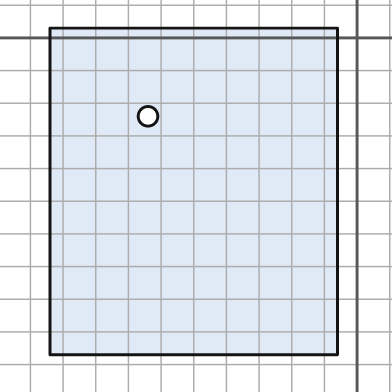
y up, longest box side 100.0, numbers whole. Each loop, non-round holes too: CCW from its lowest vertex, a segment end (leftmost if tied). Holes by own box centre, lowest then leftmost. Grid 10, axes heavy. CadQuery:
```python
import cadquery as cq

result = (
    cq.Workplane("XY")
    .moveTo(-94.0, -97.0)
    .lineTo(-6.0, -97.0)
    .lineTo(-6.0, 3.0)
    .lineTo(-94.0, 3.0)
    .close()
    .moveTo(-64.0, -24.0)
    .circle(3.0)
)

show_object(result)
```